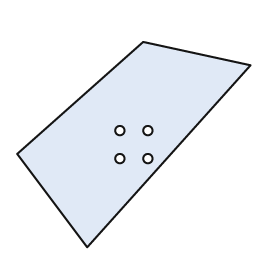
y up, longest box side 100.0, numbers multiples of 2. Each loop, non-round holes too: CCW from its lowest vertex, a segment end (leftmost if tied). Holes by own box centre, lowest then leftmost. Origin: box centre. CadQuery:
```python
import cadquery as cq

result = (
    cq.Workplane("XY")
    .moveTo(-20.0, -44.0)
    .lineTo(50.0, 34.0)
    .lineTo(4.0, 44.0)
    .lineTo(-50.0, -4.0)
    .close()
    .moveTo(-6.0, -6.0)
    .circle(2.0)
    .moveTo(6.0, -6.0)
    .circle(2.0)
    .moveTo(-6.0, 6.0)
    .circle(2.0)
    .moveTo(6.0, 6.0)
    .circle(2.0)
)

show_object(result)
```